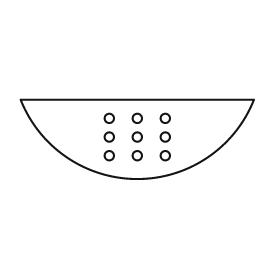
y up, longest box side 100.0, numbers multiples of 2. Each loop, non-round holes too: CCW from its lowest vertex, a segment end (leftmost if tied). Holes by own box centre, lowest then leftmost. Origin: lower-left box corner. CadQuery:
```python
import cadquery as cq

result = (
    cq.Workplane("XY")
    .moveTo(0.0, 34.0)
    .threePointArc((50.0, 0.0), (100.0, 34.0))
    .close()
    .moveTo(38.0, 10.0)
    .circle(2.0)
    .moveTo(50.0, 10.0)
    .circle(2.0)
    .moveTo(62.0, 10.0)
    .circle(2.0)
    .moveTo(38.0, 18.0)
    .circle(2.0)
    .moveTo(50.0, 18.0)
    .circle(2.0)
    .moveTo(62.0, 18.0)
    .circle(2.0)
    .moveTo(38.0, 26.0)
    .circle(2.0)
    .moveTo(50.0, 26.0)
    .circle(2.0)
    .moveTo(62.0, 26.0)
    .circle(2.0)
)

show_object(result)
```